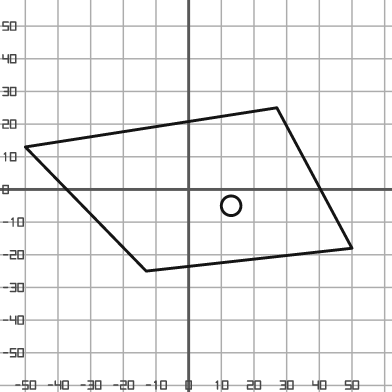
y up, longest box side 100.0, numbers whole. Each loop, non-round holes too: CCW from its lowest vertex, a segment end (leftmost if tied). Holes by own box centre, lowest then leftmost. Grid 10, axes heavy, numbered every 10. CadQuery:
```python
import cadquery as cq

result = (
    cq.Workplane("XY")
    .moveTo(-13.0, -25.0)
    .lineTo(50.0, -18.0)
    .lineTo(27.0, 25.0)
    .lineTo(-50.0, 13.0)
    .close()
    .moveTo(13.0, -5.0)
    .circle(3.0)
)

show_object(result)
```